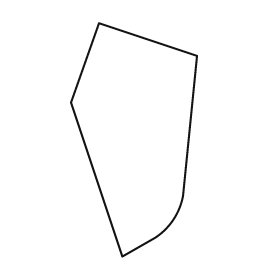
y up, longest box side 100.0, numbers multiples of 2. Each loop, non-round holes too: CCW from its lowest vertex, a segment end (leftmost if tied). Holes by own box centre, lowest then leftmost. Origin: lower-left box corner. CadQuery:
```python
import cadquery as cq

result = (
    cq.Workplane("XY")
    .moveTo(22.0, 0.0)
    .lineTo(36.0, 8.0)
    .threePointArc((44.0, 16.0), (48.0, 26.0))
    .lineTo(54.0, 86.0)
    .lineTo(12.0, 100.0)
    .lineTo(0.0, 66.0)
    .close()
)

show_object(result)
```